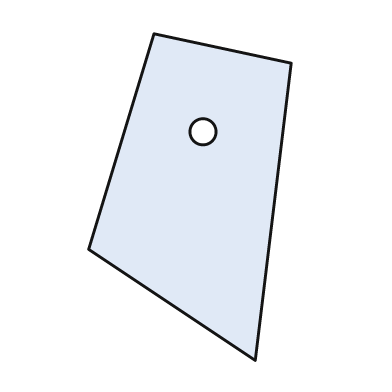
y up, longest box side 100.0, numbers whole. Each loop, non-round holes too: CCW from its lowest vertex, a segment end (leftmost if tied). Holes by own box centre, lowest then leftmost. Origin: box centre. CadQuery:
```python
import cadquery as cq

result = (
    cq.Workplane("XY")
    .moveTo(20.0, -50.0)
    .lineTo(31.0, 41.0)
    .lineTo(-11.0, 50.0)
    .lineTo(-31.0, -16.0)
    .close()
    .moveTo(4.0, 20.0)
    .circle(4.0)
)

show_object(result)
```